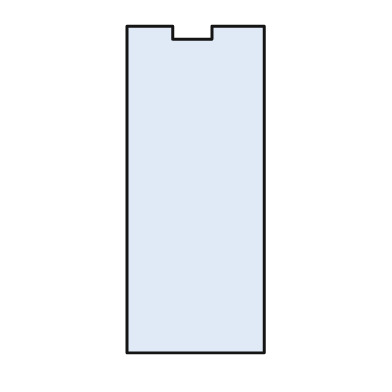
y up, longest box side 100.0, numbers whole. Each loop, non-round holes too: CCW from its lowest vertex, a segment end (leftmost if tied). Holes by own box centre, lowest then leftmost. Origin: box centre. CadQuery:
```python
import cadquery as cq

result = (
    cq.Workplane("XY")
    .moveTo(-21.0, -50.0)
    .lineTo(21.0, -50.0)
    .lineTo(21.0, 50.0)
    .lineTo(5.0, 50.0)
    .lineTo(5.0, 46.0)
    .lineTo(-7.0, 46.0)
    .lineTo(-7.0, 50.0)
    .lineTo(-21.0, 50.0)
    .close()
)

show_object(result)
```